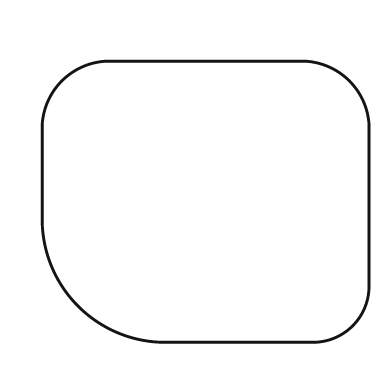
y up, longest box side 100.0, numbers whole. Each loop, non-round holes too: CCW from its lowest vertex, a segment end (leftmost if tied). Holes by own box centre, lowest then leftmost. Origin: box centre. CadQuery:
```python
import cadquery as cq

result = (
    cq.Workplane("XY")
    .moveTo(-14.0, -43.0)
    .lineTo(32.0, -43.0)
    .threePointArc((45.0, -38.0), (50.0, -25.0))
    .lineTo(50.0, 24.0)
    .threePointArc((44.0, 37.0), (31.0, 43.0))
    .lineTo(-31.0, 43.0)
    .threePointArc((-44.0, 37.0), (-50.0, 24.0))
    .lineTo(-50.0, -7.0)
    .threePointArc((-39.0, -32.0), (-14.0, -43.0))
    .close()
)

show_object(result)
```